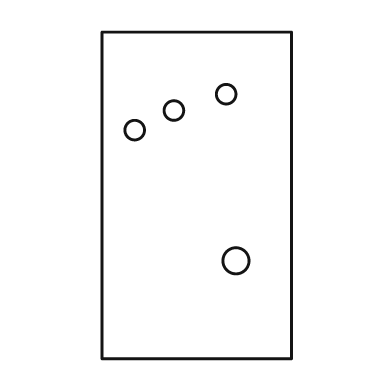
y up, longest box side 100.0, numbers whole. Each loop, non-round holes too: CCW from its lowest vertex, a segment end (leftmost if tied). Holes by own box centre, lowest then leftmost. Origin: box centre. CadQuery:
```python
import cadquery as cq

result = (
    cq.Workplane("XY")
    .moveTo(-29.0, -50.0)
    .lineTo(29.0, -50.0)
    .lineTo(29.0, 50.0)
    .lineTo(-29.0, 50.0)
    .close()
    .moveTo(12.0, -20.0)
    .circle(4.0)
    .moveTo(-19.0, 20.0)
    .circle(3.0)
    .moveTo(-7.0, 26.0)
    .circle(3.0)
    .moveTo(9.0, 31.0)
    .circle(3.0)
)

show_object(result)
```